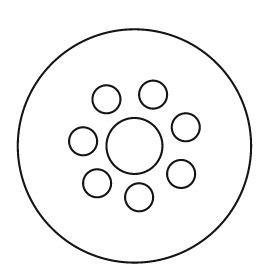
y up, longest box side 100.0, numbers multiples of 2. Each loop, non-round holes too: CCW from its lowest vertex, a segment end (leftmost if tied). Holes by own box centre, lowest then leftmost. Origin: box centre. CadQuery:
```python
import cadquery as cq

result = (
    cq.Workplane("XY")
    .moveTo(0.0, 0.0)
    .circle(50.0)
    .moveTo(2.0, -22.0)
    .circle(6.0)
    .moveTo(-16.0, -16.0)
    .circle(6.0)
    .moveTo(20.0, -12.0)
    .circle(6.0)
    .moveTo(0.0, 0.0)
    .circle(12.0)
    .moveTo(-22.0, 2.0)
    .circle(6.0)
    .moveTo(22.0, 8.0)
    .circle(6.0)
    .moveTo(-12.0, 20.0)
    .circle(6.0)
    .moveTo(8.0, 22.0)
    .circle(6.0)
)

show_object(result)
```